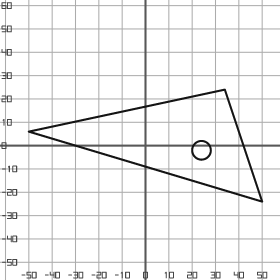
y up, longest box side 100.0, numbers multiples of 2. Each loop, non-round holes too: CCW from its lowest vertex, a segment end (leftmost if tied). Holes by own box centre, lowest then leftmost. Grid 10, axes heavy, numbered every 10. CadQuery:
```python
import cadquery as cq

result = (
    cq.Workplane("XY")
    .moveTo(50.0, -24.0)
    .lineTo(34.0, 24.0)
    .lineTo(-50.0, 6.0)
    .close()
    .moveTo(24.0, -2.0)
    .circle(4.0)
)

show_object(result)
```